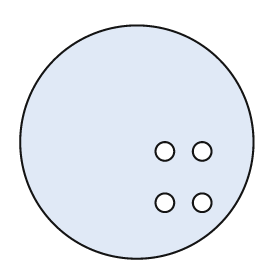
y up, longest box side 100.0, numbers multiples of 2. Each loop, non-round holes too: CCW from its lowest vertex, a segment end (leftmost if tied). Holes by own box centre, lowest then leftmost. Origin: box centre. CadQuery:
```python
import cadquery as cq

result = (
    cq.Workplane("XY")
    .moveTo(0.0, 0.0)
    .circle(50.0)
    .moveTo(12.0, -26.0)
    .circle(4.0)
    .moveTo(28.0, -26.0)
    .circle(4.0)
    .moveTo(12.0, -4.0)
    .circle(4.0)
    .moveTo(28.0, -4.0)
    .circle(4.0)
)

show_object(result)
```